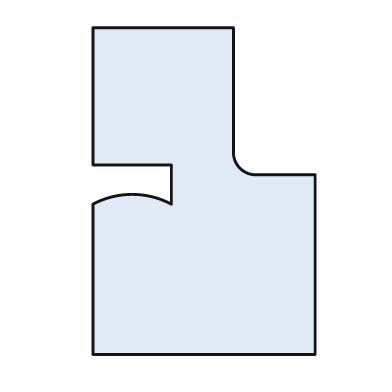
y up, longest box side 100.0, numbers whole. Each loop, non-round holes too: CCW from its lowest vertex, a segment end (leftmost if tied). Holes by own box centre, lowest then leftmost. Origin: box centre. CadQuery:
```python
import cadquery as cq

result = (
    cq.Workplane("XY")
    .moveTo(-34.0, -50.0)
    .lineTo(34.0, -50.0)
    .lineTo(34.0, 5.0)
    .lineTo(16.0, 5.0)
    .threePointArc((11.0, 7.0), (9.0, 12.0))
    .lineTo(9.0, 50.0)
    .lineTo(-34.0, 50.0)
    .lineTo(-34.0, 8.0)
    .lineTo(-10.0, 8.0)
    .lineTo(-10.0, -4.0)
    .threePointArc((-22.0, -1.0), (-34.0, -4.0))
    .close()
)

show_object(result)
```